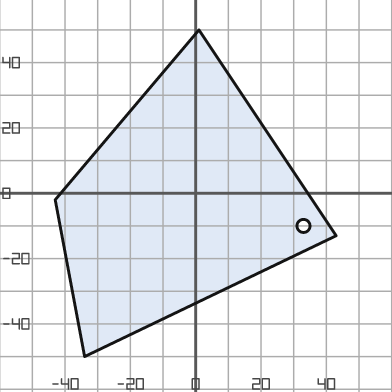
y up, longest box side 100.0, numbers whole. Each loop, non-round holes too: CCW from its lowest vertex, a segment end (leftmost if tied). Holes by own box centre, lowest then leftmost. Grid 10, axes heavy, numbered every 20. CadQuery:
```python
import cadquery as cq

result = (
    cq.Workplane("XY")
    .moveTo(-34.0, -50.0)
    .lineTo(43.0, -13.0)
    .lineTo(1.0, 50.0)
    .lineTo(-43.0, -2.0)
    .close()
    .moveTo(33.0, -10.0)
    .circle(2.0)
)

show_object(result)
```